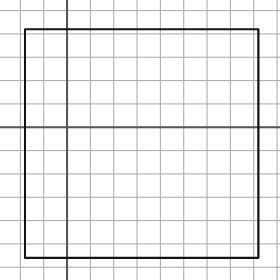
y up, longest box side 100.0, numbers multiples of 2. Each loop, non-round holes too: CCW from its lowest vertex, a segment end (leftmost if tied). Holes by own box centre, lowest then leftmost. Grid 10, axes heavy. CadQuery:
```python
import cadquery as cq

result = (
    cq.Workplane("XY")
    .moveTo(-18.0, -56.0)
    .lineTo(82.0, -56.0)
    .lineTo(82.0, 42.0)
    .lineTo(-18.0, 42.0)
    .close()
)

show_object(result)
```